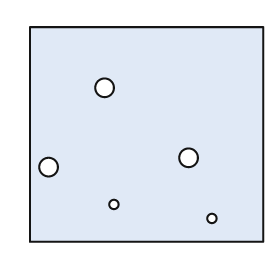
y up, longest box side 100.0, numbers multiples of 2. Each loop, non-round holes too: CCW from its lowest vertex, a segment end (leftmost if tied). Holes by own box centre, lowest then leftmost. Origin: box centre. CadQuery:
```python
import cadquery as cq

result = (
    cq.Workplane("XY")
    .moveTo(-50.0, -46.0)
    .lineTo(50.0, -46.0)
    .lineTo(50.0, 46.0)
    .lineTo(-50.0, 46.0)
    .close()
    .moveTo(28.0, -36.0)
    .circle(2.0)
    .moveTo(-14.0, -30.0)
    .circle(2.0)
    .moveTo(-42.0, -14.0)
    .circle(4.0)
    .moveTo(18.0, -10.0)
    .circle(4.0)
    .moveTo(-18.0, 20.0)
    .circle(4.0)
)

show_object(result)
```